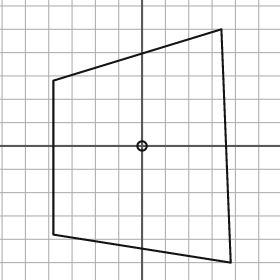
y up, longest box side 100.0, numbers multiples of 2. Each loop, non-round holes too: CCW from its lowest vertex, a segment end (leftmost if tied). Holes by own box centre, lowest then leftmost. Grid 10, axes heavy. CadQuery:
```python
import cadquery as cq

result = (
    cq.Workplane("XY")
    .moveTo(38.0, -50.0)
    .lineTo(34.0, 50.0)
    .lineTo(-38.0, 28.0)
    .lineTo(-38.0, -38.0)
    .close()
    .moveTo(0.0, 0.0)
    .circle(2.0)
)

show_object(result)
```